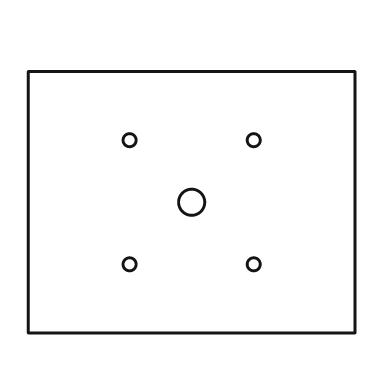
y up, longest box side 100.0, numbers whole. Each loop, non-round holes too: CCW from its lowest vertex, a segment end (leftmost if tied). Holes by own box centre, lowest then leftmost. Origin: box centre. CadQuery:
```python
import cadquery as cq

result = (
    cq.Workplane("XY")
    .moveTo(-50.0, -40.0)
    .lineTo(50.0, -40.0)
    .lineTo(50.0, 40.0)
    .lineTo(-50.0, 40.0)
    .close()
    .moveTo(-19.0, -19.0)
    .circle(2.0)
    .moveTo(19.0, -19.0)
    .circle(2.0)
    .moveTo(0.0, 0.0)
    .circle(4.0)
    .moveTo(-19.0, 19.0)
    .circle(2.0)
    .moveTo(19.0, 19.0)
    .circle(2.0)
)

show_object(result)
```